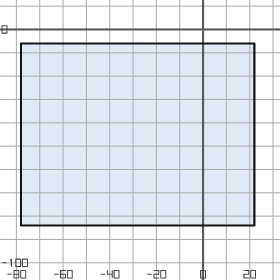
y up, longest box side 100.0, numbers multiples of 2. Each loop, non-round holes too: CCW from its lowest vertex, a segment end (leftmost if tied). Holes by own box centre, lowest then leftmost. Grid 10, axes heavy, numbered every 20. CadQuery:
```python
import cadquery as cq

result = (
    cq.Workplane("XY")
    .moveTo(-78.0, -84.0)
    .lineTo(22.0, -84.0)
    .lineTo(22.0, -6.0)
    .lineTo(-78.0, -6.0)
    .close()
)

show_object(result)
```